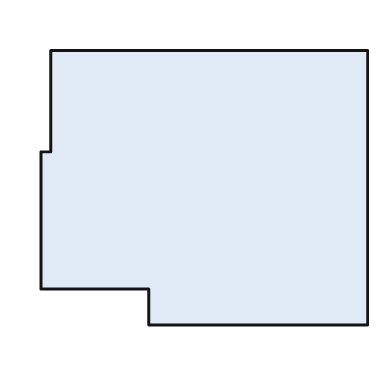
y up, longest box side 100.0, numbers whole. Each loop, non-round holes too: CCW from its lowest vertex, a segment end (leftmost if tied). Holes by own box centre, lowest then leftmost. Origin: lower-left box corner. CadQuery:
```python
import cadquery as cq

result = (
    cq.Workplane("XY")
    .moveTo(33.0, 0.0)
    .lineTo(100.0, 0.0)
    .lineTo(100.0, 84.0)
    .lineTo(3.0, 84.0)
    .lineTo(3.0, 53.0)
    .lineTo(0.0, 53.0)
    .lineTo(0.0, 11.0)
    .lineTo(33.0, 11.0)
    .close()
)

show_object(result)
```